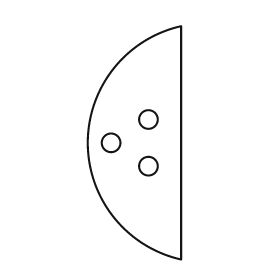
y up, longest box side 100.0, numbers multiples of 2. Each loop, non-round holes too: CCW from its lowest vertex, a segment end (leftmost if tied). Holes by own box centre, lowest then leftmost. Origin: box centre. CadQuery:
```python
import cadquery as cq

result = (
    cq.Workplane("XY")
    .moveTo(20.0, -50.0)
    .lineTo(20.0, 50.0)
    .threePointArc((-20.0, 0.0), (20.0, -50.0))
    .close()
    .moveTo(6.0, -10.0)
    .circle(4.0)
    .moveTo(-10.0, 0.0)
    .circle(4.0)
    .moveTo(6.0, 10.0)
    .circle(4.0)
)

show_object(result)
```